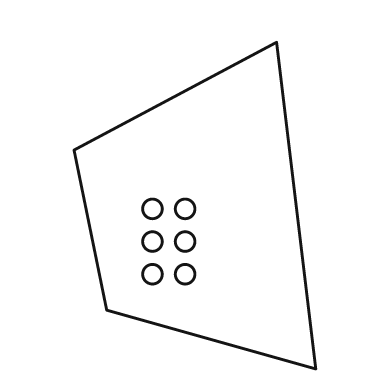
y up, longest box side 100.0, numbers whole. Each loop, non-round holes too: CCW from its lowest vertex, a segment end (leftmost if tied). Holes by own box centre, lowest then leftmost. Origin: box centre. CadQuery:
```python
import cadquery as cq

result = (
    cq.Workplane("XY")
    .moveTo(37.0, -50.0)
    .lineTo(25.0, 50.0)
    .lineTo(-37.0, 17.0)
    .lineTo(-27.0, -32.0)
    .close()
    .moveTo(-13.0, -21.0)
    .circle(3.0)
    .moveTo(-3.0, -21.0)
    .circle(3.0)
    .moveTo(-13.0, -11.0)
    .circle(3.0)
    .moveTo(-3.0, -11.0)
    .circle(3.0)
    .moveTo(-13.0, -1.0)
    .circle(3.0)
    .moveTo(-3.0, -1.0)
    .circle(3.0)
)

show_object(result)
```